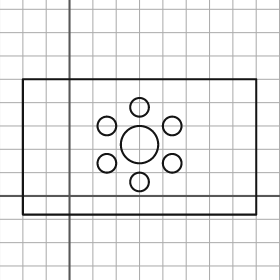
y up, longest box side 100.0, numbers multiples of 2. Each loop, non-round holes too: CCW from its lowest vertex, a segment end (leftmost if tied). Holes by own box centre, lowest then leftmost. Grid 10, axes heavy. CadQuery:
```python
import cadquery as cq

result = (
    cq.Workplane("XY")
    .moveTo(-20.0, -8.0)
    .lineTo(80.0, -8.0)
    .lineTo(80.0, 50.0)
    .lineTo(-20.0, 50.0)
    .close()
    .moveTo(30.0, 6.0)
    .circle(4.0)
    .moveTo(16.0, 14.0)
    .circle(4.0)
    .moveTo(44.0, 14.0)
    .circle(4.0)
    .moveTo(30.0, 22.0)
    .circle(8.0)
    .moveTo(16.0, 30.0)
    .circle(4.0)
    .moveTo(44.0, 30.0)
    .circle(4.0)
    .moveTo(30.0, 38.0)
    .circle(4.0)
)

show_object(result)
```